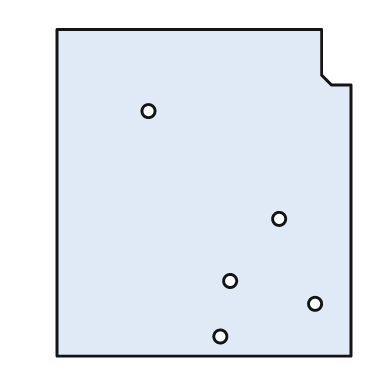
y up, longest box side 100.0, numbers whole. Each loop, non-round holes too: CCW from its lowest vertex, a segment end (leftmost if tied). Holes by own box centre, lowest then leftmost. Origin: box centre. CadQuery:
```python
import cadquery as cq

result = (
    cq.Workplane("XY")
    .moveTo(-45.0, -50.0)
    .lineTo(45.0, -50.0)
    .lineTo(45.0, 33.0)
    .lineTo(39.0, 33.0)
    .lineTo(36.0, 36.0)
    .lineTo(36.0, 50.0)
    .lineTo(-45.0, 50.0)
    .close()
    .moveTo(5.0, -44.0)
    .circle(2.0)
    .moveTo(34.0, -34.0)
    .circle(2.0)
    .moveTo(8.0, -27.0)
    .circle(2.0)
    .moveTo(23.0, -8.0)
    .circle(2.0)
    .moveTo(-17.0, 25.0)
    .circle(2.0)
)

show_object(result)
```